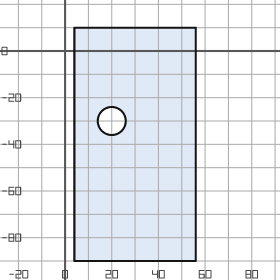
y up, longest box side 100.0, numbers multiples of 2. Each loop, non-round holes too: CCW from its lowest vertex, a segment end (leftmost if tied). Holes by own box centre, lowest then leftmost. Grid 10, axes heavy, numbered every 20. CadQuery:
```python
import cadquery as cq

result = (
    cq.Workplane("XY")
    .moveTo(4.0, -90.0)
    .lineTo(56.0, -90.0)
    .lineTo(56.0, 10.0)
    .lineTo(4.0, 10.0)
    .close()
    .moveTo(20.0, -30.0)
    .circle(6.0)
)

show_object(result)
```